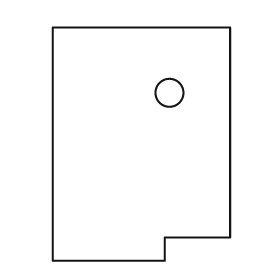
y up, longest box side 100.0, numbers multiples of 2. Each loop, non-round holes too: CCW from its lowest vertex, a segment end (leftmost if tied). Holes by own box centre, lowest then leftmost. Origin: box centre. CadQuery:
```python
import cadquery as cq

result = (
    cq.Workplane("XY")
    .moveTo(-38.0, -50.0)
    .lineTo(10.0, -50.0)
    .lineTo(10.0, -40.0)
    .lineTo(38.0, -40.0)
    .lineTo(38.0, 50.0)
    .lineTo(-38.0, 50.0)
    .close()
    .moveTo(12.0, 22.0)
    .circle(6.0)
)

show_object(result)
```